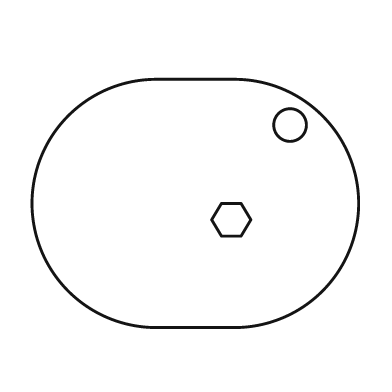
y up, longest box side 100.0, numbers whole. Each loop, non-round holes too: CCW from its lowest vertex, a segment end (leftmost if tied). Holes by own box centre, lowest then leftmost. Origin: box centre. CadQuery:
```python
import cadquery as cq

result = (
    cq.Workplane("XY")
    .moveTo(-12.0, -38.0)
    .lineTo(12.0, -38.0)
    .threePointArc((50.0, 0.0), (12.0, 38.0))
    .lineTo(-12.0, 38.0)
    .threePointArc((-50.0, 0.0), (-12.0, -38.0))
    .close()
    .moveTo(8.0, -10.0)
    .lineTo(14.0, -10.0)
    .lineTo(17.0, -5.0)
    .lineTo(14.0, 0.0)
    .lineTo(8.0, 0.0)
    .lineTo(5.0, -5.0)
    .close()
    .moveTo(29.0, 24.0)
    .circle(5.0)
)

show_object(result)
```